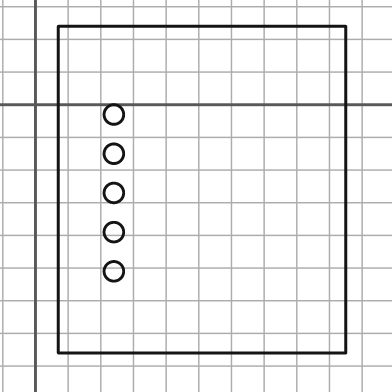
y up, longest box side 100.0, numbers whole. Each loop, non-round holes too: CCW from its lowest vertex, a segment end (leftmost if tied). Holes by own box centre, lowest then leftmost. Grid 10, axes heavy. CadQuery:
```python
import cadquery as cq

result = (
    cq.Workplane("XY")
    .moveTo(7.0, -76.0)
    .lineTo(95.0, -76.0)
    .lineTo(95.0, 24.0)
    .lineTo(7.0, 24.0)
    .close()
    .moveTo(24.0, -51.0)
    .circle(3.0)
    .moveTo(24.0, -39.0)
    .circle(3.0)
    .moveTo(24.0, -27.0)
    .circle(3.0)
    .moveTo(24.0, -15.0)
    .circle(3.0)
    .moveTo(24.0, -3.0)
    .circle(3.0)
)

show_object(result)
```